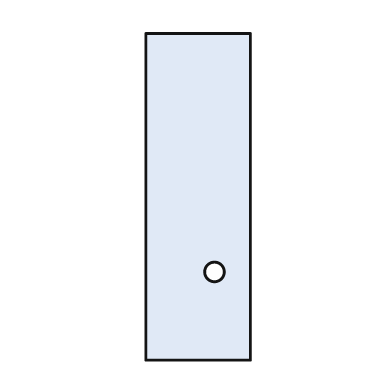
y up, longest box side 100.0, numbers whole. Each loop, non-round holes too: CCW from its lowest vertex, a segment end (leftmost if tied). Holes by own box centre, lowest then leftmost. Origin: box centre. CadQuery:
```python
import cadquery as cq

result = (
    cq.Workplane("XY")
    .moveTo(-16.0, -50.0)
    .lineTo(16.0, -50.0)
    .lineTo(16.0, 50.0)
    .lineTo(-16.0, 50.0)
    .close()
    .moveTo(5.0, -23.0)
    .circle(3.0)
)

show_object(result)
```